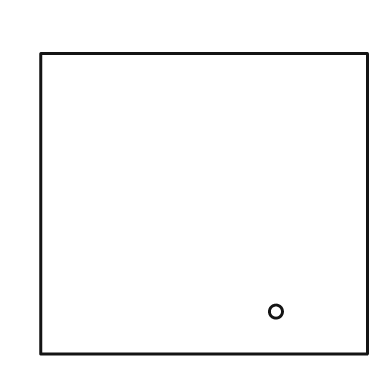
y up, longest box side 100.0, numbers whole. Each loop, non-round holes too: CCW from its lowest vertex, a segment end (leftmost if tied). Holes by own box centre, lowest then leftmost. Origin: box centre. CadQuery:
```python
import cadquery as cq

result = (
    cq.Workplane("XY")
    .moveTo(-50.0, -46.0)
    .lineTo(50.0, -46.0)
    .lineTo(50.0, 46.0)
    .lineTo(-50.0, 46.0)
    .close()
    .moveTo(22.0, -33.0)
    .circle(2.0)
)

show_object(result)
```